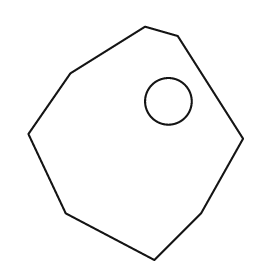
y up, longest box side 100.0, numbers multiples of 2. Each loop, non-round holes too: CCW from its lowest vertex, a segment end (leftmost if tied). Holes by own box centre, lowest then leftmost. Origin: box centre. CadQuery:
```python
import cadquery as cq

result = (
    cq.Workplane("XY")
    .moveTo(8.0, -50.0)
    .lineTo(28.0, -30.0)
    .lineTo(46.0, 2.0)
    .lineTo(18.0, 46.0)
    .lineTo(4.0, 50.0)
    .lineTo(-28.0, 30.0)
    .lineTo(-46.0, 4.0)
    .lineTo(-30.0, -30.0)
    .close()
    .moveTo(14.0, 18.0)
    .circle(10.0)
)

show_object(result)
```